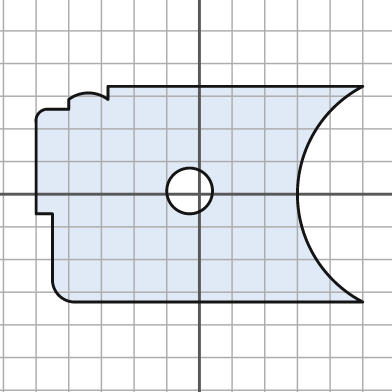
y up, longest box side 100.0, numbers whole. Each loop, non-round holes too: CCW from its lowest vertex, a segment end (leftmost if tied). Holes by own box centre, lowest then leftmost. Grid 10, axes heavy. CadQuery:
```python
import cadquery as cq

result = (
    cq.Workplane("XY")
    .moveTo(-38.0, -33.0)
    .lineTo(50.0, -33.0)
    .threePointArc((30.0, 0.0), (50.0, 33.0))
    .lineTo(-28.0, 33.0)
    .lineTo(-28.0, 29.0)
    .threePointArc((-34.0, 31.0), (-40.0, 29.0))
    .lineTo(-40.0, 26.0)
    .lineTo(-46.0, 26.0)
    .threePointArc((-49.0, 25.0), (-50.0, 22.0))
    .lineTo(-50.0, -6.0)
    .lineTo(-45.0, -6.0)
    .lineTo(-45.0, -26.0)
    .threePointArc((-43.0, -31.0), (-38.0, -33.0))
    .close()
    .moveTo(-3.0, 1.0)
    .circle(7.0)
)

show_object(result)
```